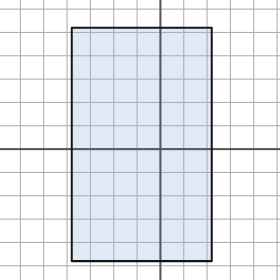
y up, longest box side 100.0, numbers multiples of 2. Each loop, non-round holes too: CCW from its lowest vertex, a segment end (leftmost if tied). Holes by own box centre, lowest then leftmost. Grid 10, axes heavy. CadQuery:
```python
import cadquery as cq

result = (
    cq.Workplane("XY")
    .moveTo(-38.0, -48.0)
    .lineTo(22.0, -48.0)
    .lineTo(22.0, 52.0)
    .lineTo(-38.0, 52.0)
    .close()
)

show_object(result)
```